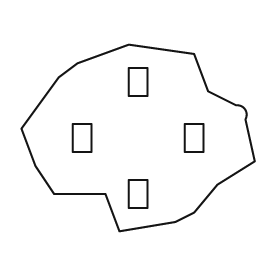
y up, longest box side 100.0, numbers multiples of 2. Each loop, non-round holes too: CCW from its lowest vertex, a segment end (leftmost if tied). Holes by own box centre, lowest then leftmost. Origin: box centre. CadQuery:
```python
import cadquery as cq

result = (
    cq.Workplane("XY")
    .moveTo(-8.0, -40.0)
    .lineTo(16.0, -36.0)
    .lineTo(24.0, -32.0)
    .lineTo(34.0, -20.0)
    .lineTo(50.0, -10.0)
    .lineTo(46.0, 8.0)
    .threePointArc((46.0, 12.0), (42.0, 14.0))
    .lineTo(30.0, 20.0)
    .lineTo(24.0, 36.0)
    .lineTo(-4.0, 40.0)
    .lineTo(-26.0, 32.0)
    .lineTo(-34.0, 26.0)
    .lineTo(-50.0, 4.0)
    .lineTo(-44.0, -12.0)
    .lineTo(-36.0, -24.0)
    .lineTo(-14.0, -24.0)
    .close()
    .moveTo(-4.0, -30.0)
    .lineTo(4.0, -30.0)
    .lineTo(4.0, -18.0)
    .lineTo(-4.0, -18.0)
    .close()
    .moveTo(-28.0, -6.0)
    .lineTo(-20.0, -6.0)
    .lineTo(-20.0, 6.0)
    .lineTo(-28.0, 6.0)
    .close()
    .moveTo(20.0, -6.0)
    .lineTo(28.0, -6.0)
    .lineTo(28.0, 6.0)
    .lineTo(20.0, 6.0)
    .close()
    .moveTo(-4.0, 18.0)
    .lineTo(4.0, 18.0)
    .lineTo(4.0, 30.0)
    .lineTo(-4.0, 30.0)
    .close()
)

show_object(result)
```